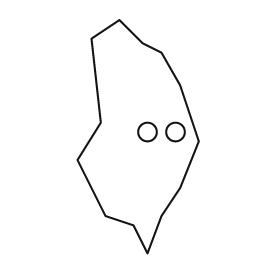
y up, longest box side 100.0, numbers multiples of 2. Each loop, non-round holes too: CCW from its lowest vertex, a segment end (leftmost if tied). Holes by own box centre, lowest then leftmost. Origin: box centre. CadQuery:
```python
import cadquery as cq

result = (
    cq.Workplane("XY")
    .moveTo(4.0, -50.0)
    .lineTo(10.0, -34.0)
    .lineTo(18.0, -22.0)
    .lineTo(26.0, -2.0)
    .lineTo(18.0, 22.0)
    .lineTo(10.0, 36.0)
    .lineTo(2.0, 40.0)
    .lineTo(-8.0, 50.0)
    .lineTo(-20.0, 42.0)
    .lineTo(-16.0, 6.0)
    .lineTo(-26.0, -10.0)
    .lineTo(-14.0, -34.0)
    .lineTo(-2.0, -38.0)
    .close()
    .moveTo(4.0, 2.0)
    .circle(4.0)
    .moveTo(16.0, 2.0)
    .circle(4.0)
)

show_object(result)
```